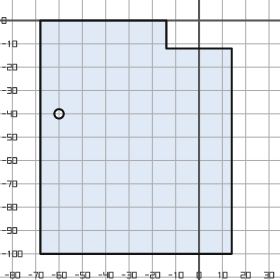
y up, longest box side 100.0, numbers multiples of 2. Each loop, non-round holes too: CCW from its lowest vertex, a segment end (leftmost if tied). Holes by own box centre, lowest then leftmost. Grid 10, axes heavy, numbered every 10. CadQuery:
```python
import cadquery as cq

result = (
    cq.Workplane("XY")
    .moveTo(-68.0, -100.0)
    .lineTo(14.0, -100.0)
    .lineTo(14.0, -12.0)
    .lineTo(-14.0, -12.0)
    .lineTo(-14.0, 0.0)
    .lineTo(-68.0, 0.0)
    .close()
    .moveTo(-60.0, -40.0)
    .circle(2.0)
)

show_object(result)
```